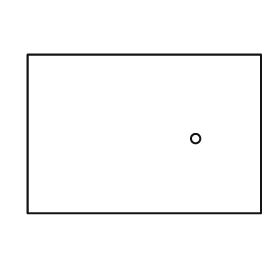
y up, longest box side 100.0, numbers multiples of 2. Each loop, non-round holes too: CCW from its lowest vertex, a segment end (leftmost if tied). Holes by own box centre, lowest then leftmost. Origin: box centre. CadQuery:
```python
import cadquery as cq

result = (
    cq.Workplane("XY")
    .moveTo(-50.0, -34.0)
    .lineTo(50.0, -34.0)
    .lineTo(50.0, 34.0)
    .lineTo(-50.0, 34.0)
    .close()
    .moveTo(22.0, -2.0)
    .circle(2.0)
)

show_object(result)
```